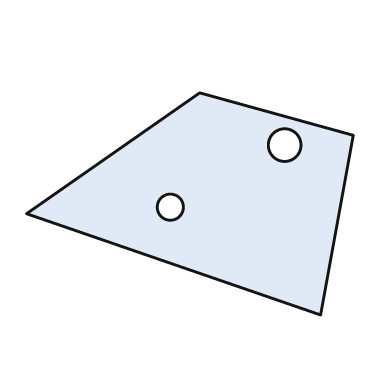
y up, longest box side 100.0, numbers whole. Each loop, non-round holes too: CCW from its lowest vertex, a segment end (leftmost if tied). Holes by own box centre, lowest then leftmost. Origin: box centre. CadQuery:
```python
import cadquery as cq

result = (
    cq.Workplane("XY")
    .moveTo(40.0, -34.0)
    .lineTo(50.0, 21.0)
    .lineTo(3.0, 34.0)
    .lineTo(-50.0, -3.0)
    .close()
    .moveTo(-6.0, -1.0)
    .circle(4.0)
    .moveTo(29.0, 18.0)
    .circle(5.0)
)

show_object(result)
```